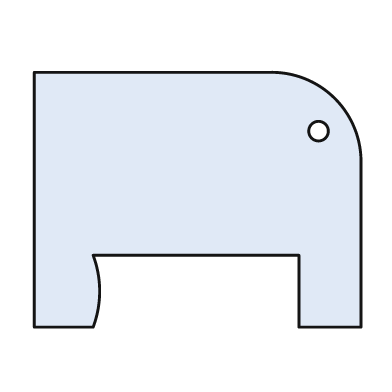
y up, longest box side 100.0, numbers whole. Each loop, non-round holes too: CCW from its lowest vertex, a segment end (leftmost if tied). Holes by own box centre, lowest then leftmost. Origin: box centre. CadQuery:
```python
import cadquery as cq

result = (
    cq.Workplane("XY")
    .moveTo(-50.0, -39.0)
    .lineTo(-32.0, -39.0)
    .threePointArc((-30.0, -28.0), (-32.0, -17.0))
    .lineTo(31.0, -17.0)
    .lineTo(31.0, -39.0)
    .lineTo(50.0, -39.0)
    .lineTo(50.0, 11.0)
    .threePointArc((42.0, 31.0), (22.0, 39.0))
    .lineTo(-50.0, 39.0)
    .close()
    .moveTo(37.0, 21.0)
    .circle(3.0)
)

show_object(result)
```